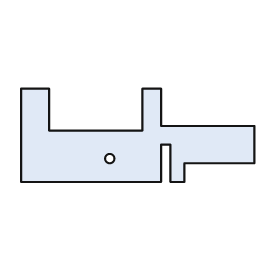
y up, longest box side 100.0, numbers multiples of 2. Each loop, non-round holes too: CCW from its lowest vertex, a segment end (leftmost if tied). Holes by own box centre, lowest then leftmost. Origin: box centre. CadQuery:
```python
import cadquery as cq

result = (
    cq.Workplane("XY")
    .moveTo(-50.0, -20.0)
    .lineTo(10.0, -20.0)
    .lineTo(10.0, -4.0)
    .lineTo(14.0, -4.0)
    .lineTo(14.0, -20.0)
    .lineTo(20.0, -20.0)
    .lineTo(20.0, -12.0)
    .lineTo(50.0, -12.0)
    .lineTo(50.0, 4.0)
    .lineTo(10.0, 4.0)
    .lineTo(10.0, 20.0)
    .lineTo(2.0, 20.0)
    .lineTo(2.0, 2.0)
    .lineTo(-38.0, 2.0)
    .lineTo(-38.0, 20.0)
    .lineTo(-50.0, 20.0)
    .close()
    .moveTo(-12.0, -10.0)
    .circle(2.0)
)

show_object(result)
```